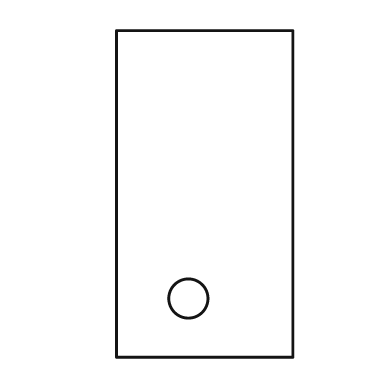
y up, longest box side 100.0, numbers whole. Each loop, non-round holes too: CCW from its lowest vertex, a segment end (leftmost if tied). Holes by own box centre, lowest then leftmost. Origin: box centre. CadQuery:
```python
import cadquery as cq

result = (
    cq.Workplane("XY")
    .moveTo(-27.0, -50.0)
    .lineTo(27.0, -50.0)
    .lineTo(27.0, 50.0)
    .lineTo(-27.0, 50.0)
    .close()
    .moveTo(-5.0, -32.0)
    .circle(6.0)
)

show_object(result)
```